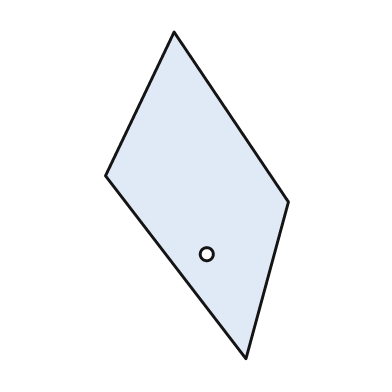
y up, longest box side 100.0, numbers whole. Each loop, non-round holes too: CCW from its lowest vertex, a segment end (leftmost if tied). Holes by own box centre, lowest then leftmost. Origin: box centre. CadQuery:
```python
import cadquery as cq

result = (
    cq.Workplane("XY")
    .moveTo(15.0, -50.0)
    .lineTo(28.0, -2.0)
    .lineTo(-7.0, 50.0)
    .lineTo(-28.0, 6.0)
    .close()
    .moveTo(3.0, -18.0)
    .circle(2.0)
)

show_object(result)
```